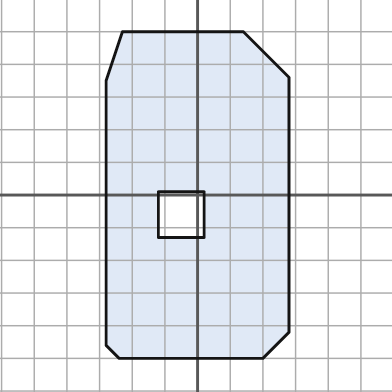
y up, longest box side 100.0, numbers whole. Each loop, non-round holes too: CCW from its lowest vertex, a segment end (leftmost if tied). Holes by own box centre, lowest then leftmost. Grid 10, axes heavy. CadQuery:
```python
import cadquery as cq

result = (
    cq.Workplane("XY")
    .moveTo(-24.0, -50.0)
    .lineTo(20.0, -50.0)
    .lineTo(28.0, -42.0)
    .lineTo(28.0, 36.0)
    .lineTo(14.0, 50.0)
    .lineTo(-23.0, 50.0)
    .lineTo(-28.0, 35.0)
    .lineTo(-28.0, -46.0)
    .close()
    .moveTo(-12.0, -13.0)
    .lineTo(2.0, -13.0)
    .lineTo(2.0, 1.0)
    .lineTo(-12.0, 1.0)
    .close()
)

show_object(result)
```